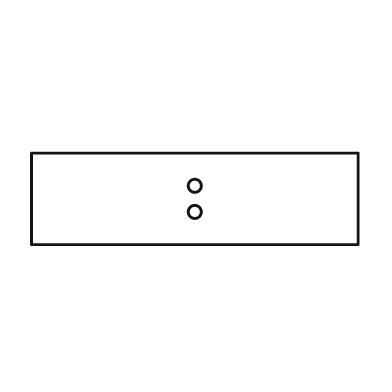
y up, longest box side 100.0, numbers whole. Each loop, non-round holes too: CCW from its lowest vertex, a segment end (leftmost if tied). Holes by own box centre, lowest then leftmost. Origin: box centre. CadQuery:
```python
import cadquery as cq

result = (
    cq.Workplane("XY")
    .moveTo(-50.0, -14.0)
    .lineTo(50.0, -14.0)
    .lineTo(50.0, 14.0)
    .lineTo(-50.0, 14.0)
    .close()
    .moveTo(0.0, -4.0)
    .circle(2.0)
    .moveTo(0.0, 4.0)
    .circle(2.0)
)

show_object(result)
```